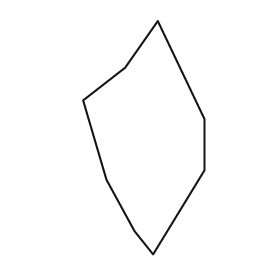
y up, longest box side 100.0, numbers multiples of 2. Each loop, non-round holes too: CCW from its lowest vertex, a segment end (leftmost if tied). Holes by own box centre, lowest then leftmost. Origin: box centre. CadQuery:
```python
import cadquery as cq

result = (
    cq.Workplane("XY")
    .moveTo(4.0, -50.0)
    .lineTo(26.0, -14.0)
    .lineTo(26.0, 8.0)
    .lineTo(6.0, 50.0)
    .lineTo(-8.0, 30.0)
    .lineTo(-26.0, 16.0)
    .lineTo(-16.0, -18.0)
    .lineTo(-4.0, -40.0)
    .close()
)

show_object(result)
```